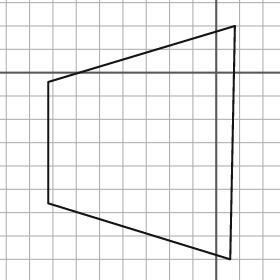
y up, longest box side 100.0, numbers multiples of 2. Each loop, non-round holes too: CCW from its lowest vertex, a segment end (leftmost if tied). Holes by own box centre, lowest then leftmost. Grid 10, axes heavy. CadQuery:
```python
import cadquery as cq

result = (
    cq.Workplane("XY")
    .moveTo(6.0, -80.0)
    .lineTo(8.0, 20.0)
    .lineTo(-72.0, -4.0)
    .lineTo(-72.0, -56.0)
    .close()
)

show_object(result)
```